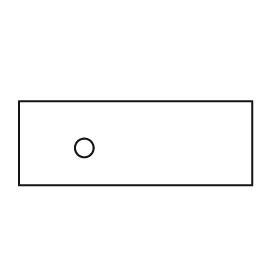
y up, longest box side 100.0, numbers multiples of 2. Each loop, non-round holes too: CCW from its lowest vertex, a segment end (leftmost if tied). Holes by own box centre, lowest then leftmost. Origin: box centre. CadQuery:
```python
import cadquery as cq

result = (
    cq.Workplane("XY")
    .moveTo(-50.0, -18.0)
    .lineTo(50.0, -18.0)
    .lineTo(50.0, 18.0)
    .lineTo(-50.0, 18.0)
    .close()
    .moveTo(-22.0, -2.0)
    .circle(4.0)
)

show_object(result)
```